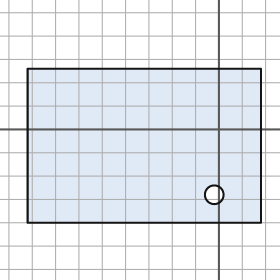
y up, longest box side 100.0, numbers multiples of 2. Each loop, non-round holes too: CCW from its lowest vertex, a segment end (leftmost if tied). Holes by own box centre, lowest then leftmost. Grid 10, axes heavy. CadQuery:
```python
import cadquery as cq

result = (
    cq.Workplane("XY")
    .moveTo(-82.0, -40.0)
    .lineTo(18.0, -40.0)
    .lineTo(18.0, 26.0)
    .lineTo(-82.0, 26.0)
    .close()
    .moveTo(-2.0, -28.0)
    .circle(4.0)
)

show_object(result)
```